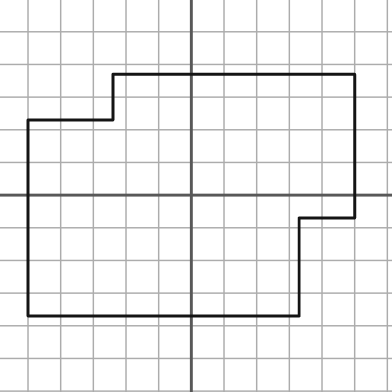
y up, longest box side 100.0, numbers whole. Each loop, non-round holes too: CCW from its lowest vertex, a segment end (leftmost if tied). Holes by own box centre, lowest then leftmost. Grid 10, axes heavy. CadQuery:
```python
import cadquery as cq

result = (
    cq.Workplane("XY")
    .moveTo(-50.0, -37.0)
    .lineTo(33.0, -37.0)
    .lineTo(33.0, -7.0)
    .lineTo(50.0, -7.0)
    .lineTo(50.0, 37.0)
    .lineTo(-24.0, 37.0)
    .lineTo(-24.0, 23.0)
    .lineTo(-50.0, 23.0)
    .close()
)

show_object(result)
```